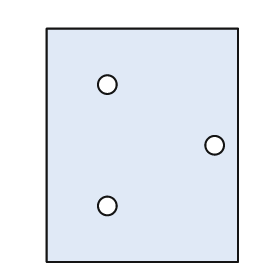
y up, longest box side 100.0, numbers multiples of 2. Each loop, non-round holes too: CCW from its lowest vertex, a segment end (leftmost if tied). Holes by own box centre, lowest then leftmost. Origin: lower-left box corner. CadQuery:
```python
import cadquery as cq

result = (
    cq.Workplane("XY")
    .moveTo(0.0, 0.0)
    .lineTo(82.0, 0.0)
    .lineTo(82.0, 100.0)
    .lineTo(0.0, 100.0)
    .close()
    .moveTo(26.0, 24.0)
    .circle(4.0)
    .moveTo(72.0, 50.0)
    .circle(4.0)
    .moveTo(26.0, 76.0)
    .circle(4.0)
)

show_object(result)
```